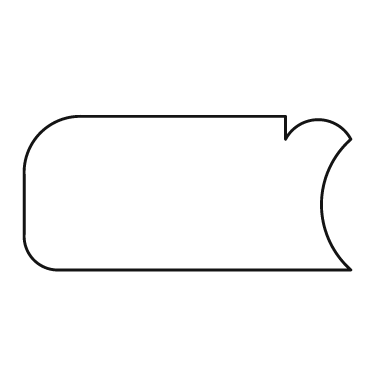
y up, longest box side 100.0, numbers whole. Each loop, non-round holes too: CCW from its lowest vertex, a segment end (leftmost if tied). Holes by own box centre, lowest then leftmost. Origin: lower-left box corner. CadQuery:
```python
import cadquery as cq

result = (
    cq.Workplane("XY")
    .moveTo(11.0, 0.0)
    .lineTo(100.0, 0.0)
    .threePointArc((91.0, 20.0), (100.0, 40.0))
    .threePointArc((90.0, 46.0), (80.0, 40.0))
    .lineTo(80.0, 47.0)
    .lineTo(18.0, 47.0)
    .threePointArc((5.0, 42.0), (0.0, 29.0))
    .lineTo(0.0, 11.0)
    .threePointArc((3.0, 3.0), (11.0, 0.0))
    .close()
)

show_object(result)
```